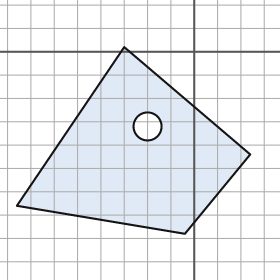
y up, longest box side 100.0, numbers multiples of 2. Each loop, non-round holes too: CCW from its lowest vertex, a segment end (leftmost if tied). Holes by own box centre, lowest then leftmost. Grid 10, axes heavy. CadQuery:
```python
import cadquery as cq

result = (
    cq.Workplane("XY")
    .moveTo(-4.0, -78.0)
    .lineTo(24.0, -44.0)
    .lineTo(-30.0, 2.0)
    .lineTo(-76.0, -66.0)
    .close()
    .moveTo(-20.0, -32.0)
    .circle(6.0)
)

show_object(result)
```